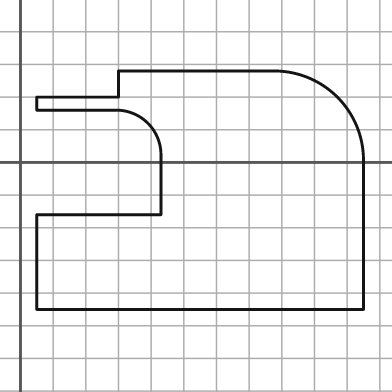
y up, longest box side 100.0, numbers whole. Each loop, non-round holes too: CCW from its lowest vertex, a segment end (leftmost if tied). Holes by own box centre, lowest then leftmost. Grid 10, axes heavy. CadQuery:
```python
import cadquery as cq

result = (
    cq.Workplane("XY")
    .moveTo(5.0, -45.0)
    .lineTo(105.0, -45.0)
    .lineTo(105.0, 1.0)
    .threePointArc((97.0, 20.0), (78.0, 28.0))
    .lineTo(30.0, 28.0)
    .lineTo(30.0, 20.0)
    .lineTo(5.0, 20.0)
    .lineTo(5.0, 16.0)
    .lineTo(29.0, 16.0)
    .threePointArc((39.0, 12.0), (43.0, 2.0))
    .lineTo(43.0, -16.0)
    .lineTo(5.0, -16.0)
    .close()
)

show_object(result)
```